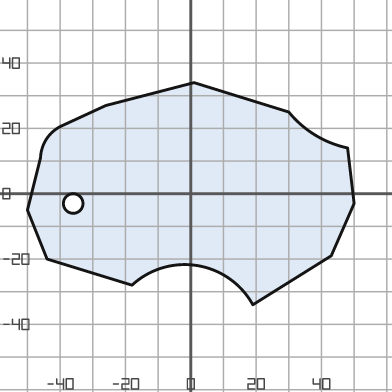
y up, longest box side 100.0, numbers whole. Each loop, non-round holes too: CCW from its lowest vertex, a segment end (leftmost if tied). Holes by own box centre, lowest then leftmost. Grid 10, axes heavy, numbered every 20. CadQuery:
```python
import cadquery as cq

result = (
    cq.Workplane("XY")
    .moveTo(19.0, -34.0)
    .lineTo(43.0, -19.0)
    .lineTo(50.0, -3.0)
    .lineTo(48.0, 14.0)
    .threePointArc((38.0, 18.0), (30.0, 25.0))
    .lineTo(1.0, 34.0)
    .lineTo(-26.0, 27.0)
    .lineTo(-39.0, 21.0)
    .threePointArc((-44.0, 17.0), (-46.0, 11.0))
    .lineTo(-50.0, -5.0)
    .lineTo(-44.0, -20.0)
    .lineTo(-18.0, -28.0)
    .threePointArc((2.0, -22.0), (19.0, -34.0))
    .close()
    .moveTo(-36.0, -3.0)
    .circle(3.0)
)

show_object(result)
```